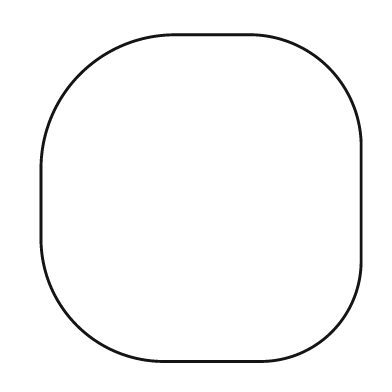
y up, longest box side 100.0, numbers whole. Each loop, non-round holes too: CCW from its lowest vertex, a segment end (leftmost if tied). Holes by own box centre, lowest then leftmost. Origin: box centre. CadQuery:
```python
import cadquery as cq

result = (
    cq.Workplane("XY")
    .moveTo(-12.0, -50.0)
    .lineTo(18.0, -50.0)
    .threePointArc((40.0, -41.0), (49.0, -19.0))
    .lineTo(49.0, 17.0)
    .threePointArc((39.0, 40.0), (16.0, 50.0))
    .lineTo(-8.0, 50.0)
    .threePointArc((-37.0, 38.0), (-49.0, 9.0))
    .lineTo(-49.0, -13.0)
    .threePointArc((-38.0, -39.0), (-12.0, -50.0))
    .close()
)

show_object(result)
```